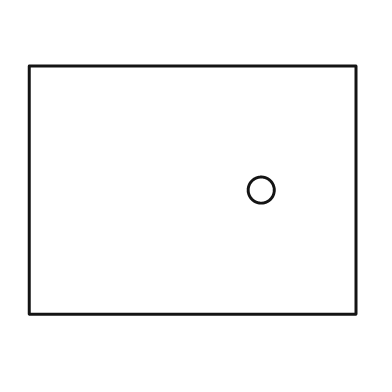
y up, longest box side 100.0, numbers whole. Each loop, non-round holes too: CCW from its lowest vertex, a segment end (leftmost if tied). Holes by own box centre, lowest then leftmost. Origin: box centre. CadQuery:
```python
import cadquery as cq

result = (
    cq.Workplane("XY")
    .moveTo(-50.0, -38.0)
    .lineTo(50.0, -38.0)
    .lineTo(50.0, 38.0)
    .lineTo(-50.0, 38.0)
    .close()
    .moveTo(21.0, 0.0)
    .circle(4.0)
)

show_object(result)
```